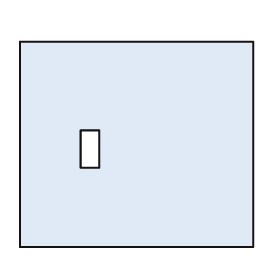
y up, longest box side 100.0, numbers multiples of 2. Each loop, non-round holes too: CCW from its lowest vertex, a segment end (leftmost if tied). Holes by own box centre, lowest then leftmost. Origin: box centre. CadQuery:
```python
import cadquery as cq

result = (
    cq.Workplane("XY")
    .moveTo(-50.0, -44.0)
    .lineTo(50.0, -44.0)
    .lineTo(50.0, 44.0)
    .lineTo(-50.0, 44.0)
    .close()
    .moveTo(-24.0, -10.0)
    .lineTo(-16.0, -10.0)
    .lineTo(-16.0, 6.0)
    .lineTo(-24.0, 6.0)
    .close()
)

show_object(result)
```